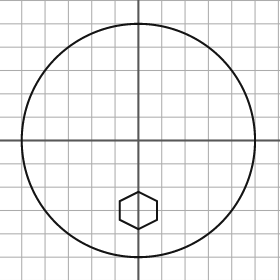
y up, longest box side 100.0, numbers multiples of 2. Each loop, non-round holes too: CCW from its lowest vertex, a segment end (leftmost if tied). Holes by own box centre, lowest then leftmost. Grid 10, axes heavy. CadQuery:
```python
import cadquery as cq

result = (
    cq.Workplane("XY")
    .moveTo(0.0, 0.0)
    .circle(50.0)
    .moveTo(0.0, -38.0)
    .lineTo(8.0, -34.0)
    .lineTo(8.0, -26.0)
    .lineTo(0.0, -22.0)
    .lineTo(-8.0, -26.0)
    .lineTo(-8.0, -34.0)
    .close()
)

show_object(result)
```